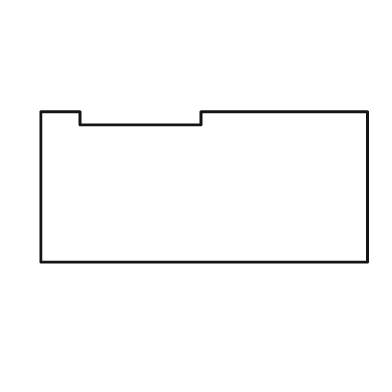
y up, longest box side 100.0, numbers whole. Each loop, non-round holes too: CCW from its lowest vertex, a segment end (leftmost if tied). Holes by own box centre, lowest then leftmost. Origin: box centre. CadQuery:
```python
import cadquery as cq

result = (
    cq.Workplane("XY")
    .moveTo(-50.0, -23.0)
    .lineTo(50.0, -23.0)
    .lineTo(50.0, 23.0)
    .lineTo(-1.0, 23.0)
    .lineTo(-1.0, 19.0)
    .lineTo(-38.0, 19.0)
    .lineTo(-38.0, 23.0)
    .lineTo(-50.0, 23.0)
    .close()
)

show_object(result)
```